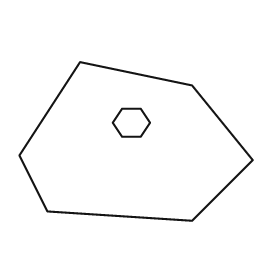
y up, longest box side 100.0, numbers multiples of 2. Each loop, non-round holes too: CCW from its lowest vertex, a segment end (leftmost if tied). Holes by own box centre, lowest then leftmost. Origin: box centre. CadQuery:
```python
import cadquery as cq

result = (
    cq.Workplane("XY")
    .moveTo(24.0, -34.0)
    .lineTo(50.0, -8.0)
    .lineTo(24.0, 24.0)
    .lineTo(-24.0, 34.0)
    .lineTo(-50.0, -6.0)
    .lineTo(-38.0, -30.0)
    .close()
    .moveTo(-6.0, 2.0)
    .lineTo(2.0, 2.0)
    .lineTo(6.0, 8.0)
    .lineTo(2.0, 14.0)
    .lineTo(-6.0, 14.0)
    .lineTo(-10.0, 8.0)
    .close()
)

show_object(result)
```